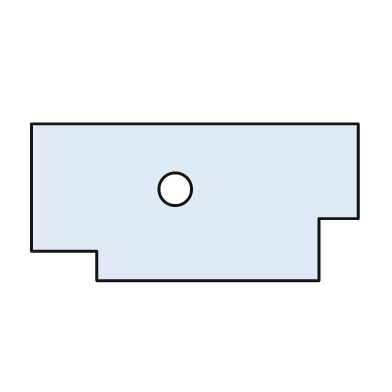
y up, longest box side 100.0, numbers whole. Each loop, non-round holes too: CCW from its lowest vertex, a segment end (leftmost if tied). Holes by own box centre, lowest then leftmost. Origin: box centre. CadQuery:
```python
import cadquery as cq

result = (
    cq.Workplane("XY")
    .moveTo(-30.0, -24.0)
    .lineTo(38.0, -24.0)
    .lineTo(38.0, -5.0)
    .lineTo(50.0, -5.0)
    .lineTo(50.0, 24.0)
    .lineTo(-50.0, 24.0)
    .lineTo(-50.0, -15.0)
    .lineTo(-30.0, -15.0)
    .close()
    .moveTo(-6.0, 4.0)
    .circle(5.0)
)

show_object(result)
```